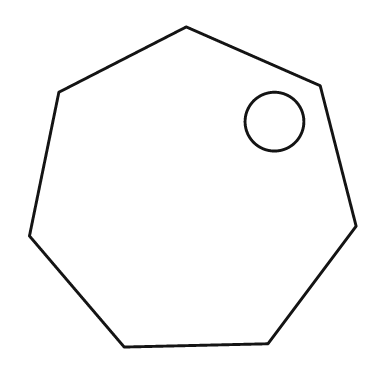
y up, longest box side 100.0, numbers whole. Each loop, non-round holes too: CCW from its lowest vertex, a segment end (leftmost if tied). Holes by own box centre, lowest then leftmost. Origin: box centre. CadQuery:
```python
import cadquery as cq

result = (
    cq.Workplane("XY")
    .moveTo(-21.0, -49.0)
    .lineTo(23.0, -48.0)
    .lineTo(50.0, -12.0)
    .lineTo(39.0, 31.0)
    .lineTo(-2.0, 49.0)
    .lineTo(-41.0, 29.0)
    .lineTo(-50.0, -15.0)
    .close()
    .moveTo(25.0, 20.0)
    .circle(9.0)
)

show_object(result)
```